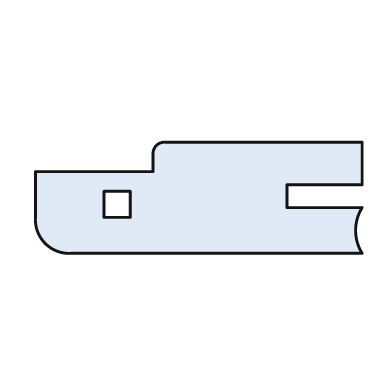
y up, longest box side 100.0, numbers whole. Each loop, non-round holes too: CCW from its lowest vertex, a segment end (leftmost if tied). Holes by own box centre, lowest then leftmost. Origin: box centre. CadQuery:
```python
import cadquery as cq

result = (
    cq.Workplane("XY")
    .moveTo(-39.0, -17.0)
    .lineTo(50.0, -17.0)
    .threePointArc((48.0, -10.0), (50.0, -3.0))
    .lineTo(27.0, -3.0)
    .lineTo(27.0, 4.0)
    .lineTo(50.0, 4.0)
    .lineTo(50.0, 17.0)
    .lineTo(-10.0, 17.0)
    .threePointArc((-13.0, 16.0), (-14.0, 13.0))
    .lineTo(-14.0, 8.0)
    .lineTo(-50.0, 8.0)
    .lineTo(-50.0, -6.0)
    .threePointArc((-47.0, -14.0), (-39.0, -17.0))
    .close()
    .moveTo(-29.0, -6.0)
    .lineTo(-21.0, -6.0)
    .lineTo(-21.0, 2.0)
    .lineTo(-29.0, 2.0)
    .close()
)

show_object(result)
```